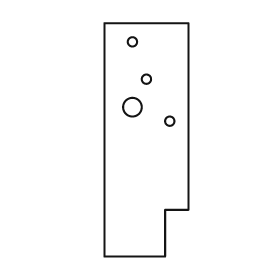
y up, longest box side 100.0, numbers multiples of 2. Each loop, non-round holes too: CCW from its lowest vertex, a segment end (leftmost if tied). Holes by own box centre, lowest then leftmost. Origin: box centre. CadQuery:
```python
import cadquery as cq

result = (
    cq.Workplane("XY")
    .moveTo(-18.0, -50.0)
    .lineTo(8.0, -50.0)
    .lineTo(8.0, -30.0)
    .lineTo(18.0, -30.0)
    .lineTo(18.0, 50.0)
    .lineTo(-18.0, 50.0)
    .close()
    .moveTo(10.0, 8.0)
    .circle(2.0)
    .moveTo(-6.0, 14.0)
    .circle(4.0)
    .moveTo(0.0, 26.0)
    .circle(2.0)
    .moveTo(-6.0, 42.0)
    .circle(2.0)
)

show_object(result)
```